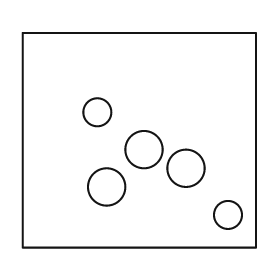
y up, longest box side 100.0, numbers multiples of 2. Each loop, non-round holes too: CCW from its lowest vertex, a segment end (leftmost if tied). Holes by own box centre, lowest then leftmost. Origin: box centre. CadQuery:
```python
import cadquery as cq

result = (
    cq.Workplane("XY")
    .moveTo(-50.0, -46.0)
    .lineTo(50.0, -46.0)
    .lineTo(50.0, 46.0)
    .lineTo(-50.0, 46.0)
    .close()
    .moveTo(38.0, -32.0)
    .circle(6.0)
    .moveTo(-14.0, -20.0)
    .circle(8.0)
    .moveTo(20.0, -12.0)
    .circle(8.0)
    .moveTo(2.0, -4.0)
    .circle(8.0)
    .moveTo(-18.0, 12.0)
    .circle(6.0)
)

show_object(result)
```